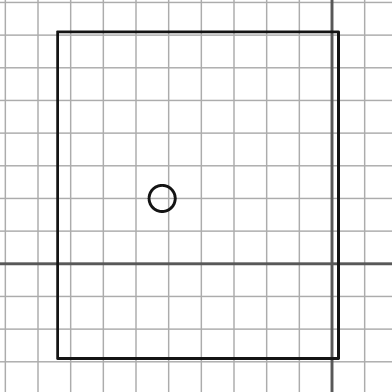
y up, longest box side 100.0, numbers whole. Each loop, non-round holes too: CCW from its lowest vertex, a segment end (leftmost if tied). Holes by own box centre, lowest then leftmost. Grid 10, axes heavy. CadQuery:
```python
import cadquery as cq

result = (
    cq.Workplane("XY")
    .moveTo(-84.0, -29.0)
    .lineTo(2.0, -29.0)
    .lineTo(2.0, 71.0)
    .lineTo(-84.0, 71.0)
    .close()
    .moveTo(-52.0, 20.0)
    .circle(4.0)
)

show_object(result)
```